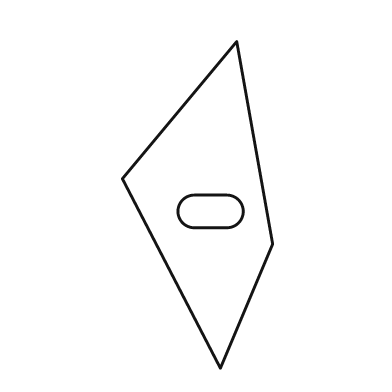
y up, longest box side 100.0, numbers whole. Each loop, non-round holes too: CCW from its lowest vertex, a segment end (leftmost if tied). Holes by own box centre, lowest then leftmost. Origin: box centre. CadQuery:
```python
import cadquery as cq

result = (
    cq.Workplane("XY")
    .moveTo(7.0, -50.0)
    .lineTo(23.0, -12.0)
    .lineTo(12.0, 50.0)
    .lineTo(-23.0, 8.0)
    .close()
    .moveTo(-1.0, -7.0)
    .lineTo(9.0, -7.0)
    .threePointArc((14.0, -2.0), (9.0, 3.0))
    .lineTo(-1.0, 3.0)
    .threePointArc((-6.0, -2.0), (-1.0, -7.0))
    .close()
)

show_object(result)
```